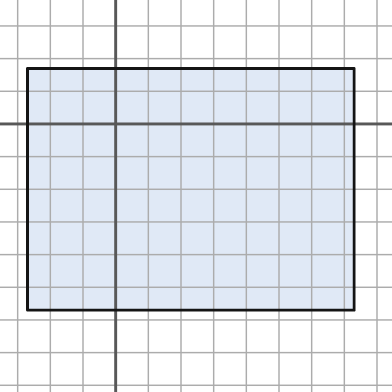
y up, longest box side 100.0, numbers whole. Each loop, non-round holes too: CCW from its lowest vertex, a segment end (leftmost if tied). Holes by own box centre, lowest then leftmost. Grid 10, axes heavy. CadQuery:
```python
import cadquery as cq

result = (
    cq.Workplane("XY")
    .moveTo(-27.0, -57.0)
    .lineTo(73.0, -57.0)
    .lineTo(73.0, 17.0)
    .lineTo(-27.0, 17.0)
    .close()
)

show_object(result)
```